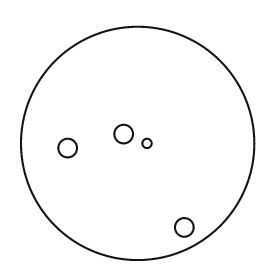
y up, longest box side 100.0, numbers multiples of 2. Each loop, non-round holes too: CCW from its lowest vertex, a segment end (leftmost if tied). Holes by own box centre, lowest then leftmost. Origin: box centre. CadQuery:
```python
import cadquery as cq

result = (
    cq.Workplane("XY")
    .moveTo(0.0, 0.0)
    .circle(50.0)
    .moveTo(20.0, -36.0)
    .circle(4.0)
    .moveTo(-30.0, -2.0)
    .circle(4.0)
    .moveTo(4.0, 0.0)
    .circle(2.0)
    .moveTo(-6.0, 4.0)
    .circle(4.0)
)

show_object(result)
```